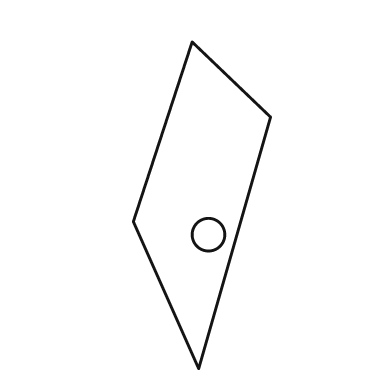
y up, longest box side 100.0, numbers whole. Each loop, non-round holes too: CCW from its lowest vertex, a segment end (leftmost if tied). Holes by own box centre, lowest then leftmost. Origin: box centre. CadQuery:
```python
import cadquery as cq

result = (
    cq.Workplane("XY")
    .moveTo(-1.0, -50.0)
    .lineTo(21.0, 27.0)
    .lineTo(-3.0, 50.0)
    .lineTo(-21.0, -5.0)
    .close()
    .moveTo(2.0, -9.0)
    .circle(5.0)
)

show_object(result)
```